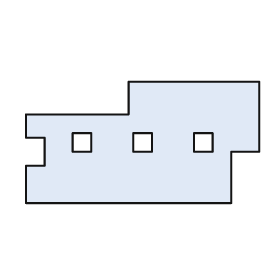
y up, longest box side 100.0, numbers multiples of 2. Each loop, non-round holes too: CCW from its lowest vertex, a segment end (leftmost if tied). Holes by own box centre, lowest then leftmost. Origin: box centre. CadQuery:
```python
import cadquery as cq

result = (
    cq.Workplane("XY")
    .moveTo(-50.0, -26.0)
    .lineTo(38.0, -26.0)
    .lineTo(38.0, -4.0)
    .lineTo(50.0, -4.0)
    .lineTo(50.0, 26.0)
    .lineTo(-6.0, 26.0)
    .lineTo(-6.0, 12.0)
    .lineTo(-50.0, 12.0)
    .lineTo(-50.0, 2.0)
    .lineTo(-42.0, 2.0)
    .lineTo(-42.0, -10.0)
    .lineTo(-50.0, -10.0)
    .close()
    .moveTo(-30.0, -4.0)
    .lineTo(-22.0, -4.0)
    .lineTo(-22.0, 4.0)
    .lineTo(-30.0, 4.0)
    .close()
    .moveTo(-4.0, -4.0)
    .lineTo(4.0, -4.0)
    .lineTo(4.0, 4.0)
    .lineTo(-4.0, 4.0)
    .close()
    .moveTo(22.0, -4.0)
    .lineTo(30.0, -4.0)
    .lineTo(30.0, 4.0)
    .lineTo(22.0, 4.0)
    .close()
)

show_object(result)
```